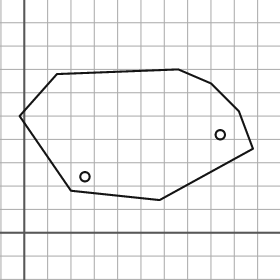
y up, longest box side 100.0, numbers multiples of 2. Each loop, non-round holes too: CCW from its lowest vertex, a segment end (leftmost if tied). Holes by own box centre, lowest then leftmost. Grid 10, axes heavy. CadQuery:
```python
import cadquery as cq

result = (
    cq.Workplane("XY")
    .moveTo(58.0, 14.0)
    .lineTo(98.0, 36.0)
    .lineTo(92.0, 52.0)
    .lineTo(80.0, 64.0)
    .lineTo(66.0, 70.0)
    .lineTo(14.0, 68.0)
    .lineTo(-2.0, 50.0)
    .lineTo(20.0, 18.0)
    .close()
    .moveTo(26.0, 24.0)
    .circle(2.0)
    .moveTo(84.0, 42.0)
    .circle(2.0)
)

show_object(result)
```